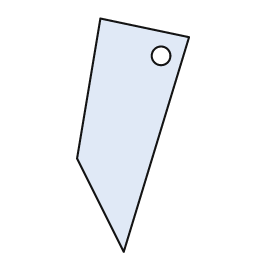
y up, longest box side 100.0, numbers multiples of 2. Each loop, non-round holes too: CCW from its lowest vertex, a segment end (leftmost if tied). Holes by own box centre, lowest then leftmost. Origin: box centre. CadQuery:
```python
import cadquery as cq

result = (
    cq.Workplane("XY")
    .moveTo(-4.0, -50.0)
    .lineTo(24.0, 42.0)
    .lineTo(-14.0, 50.0)
    .lineTo(-24.0, -10.0)
    .close()
    .moveTo(12.0, 34.0)
    .circle(4.0)
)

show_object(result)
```